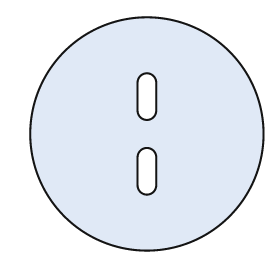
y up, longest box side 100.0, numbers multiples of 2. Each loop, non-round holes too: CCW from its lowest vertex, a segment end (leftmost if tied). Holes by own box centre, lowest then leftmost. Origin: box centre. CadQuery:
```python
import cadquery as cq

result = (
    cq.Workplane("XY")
    .moveTo(0.0, 0.0)
    .circle(50.0)
    .moveTo(-4.0, -22.0)
    .threePointArc((0.0, -26.0), (4.0, -22.0))
    .lineTo(4.0, -10.0)
    .threePointArc((0.0, -6.0), (-4.0, -10.0))
    .close()
    .moveTo(-4.0, 10.0)
    .threePointArc((0.0, 6.0), (4.0, 10.0))
    .lineTo(4.0, 22.0)
    .threePointArc((0.0, 26.0), (-4.0, 22.0))
    .close()
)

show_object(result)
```